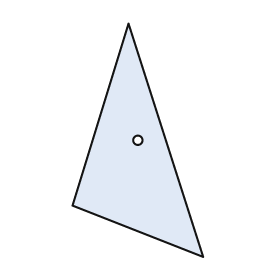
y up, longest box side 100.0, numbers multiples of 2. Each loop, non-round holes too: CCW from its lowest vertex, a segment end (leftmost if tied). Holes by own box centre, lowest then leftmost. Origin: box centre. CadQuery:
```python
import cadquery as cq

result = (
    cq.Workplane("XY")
    .moveTo(28.0, -50.0)
    .lineTo(-4.0, 50.0)
    .lineTo(-28.0, -28.0)
    .close()
    .moveTo(0.0, 0.0)
    .circle(2.0)
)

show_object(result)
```